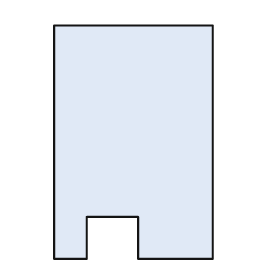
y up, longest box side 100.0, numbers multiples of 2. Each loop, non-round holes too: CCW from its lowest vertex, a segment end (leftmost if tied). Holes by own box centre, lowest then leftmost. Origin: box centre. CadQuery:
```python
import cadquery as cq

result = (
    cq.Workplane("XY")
    .moveTo(-34.0, -50.0)
    .lineTo(-20.0, -50.0)
    .lineTo(-20.0, -32.0)
    .lineTo(2.0, -32.0)
    .lineTo(2.0, -50.0)
    .lineTo(34.0, -50.0)
    .lineTo(34.0, 50.0)
    .lineTo(-34.0, 50.0)
    .close()
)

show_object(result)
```